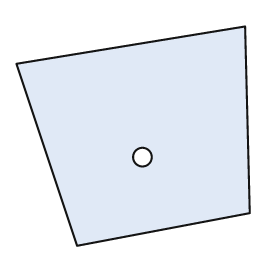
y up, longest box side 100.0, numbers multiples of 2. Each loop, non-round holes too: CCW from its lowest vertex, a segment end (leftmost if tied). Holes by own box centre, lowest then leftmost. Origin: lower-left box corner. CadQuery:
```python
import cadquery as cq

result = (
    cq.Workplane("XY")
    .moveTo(26.0, 0.0)
    .lineTo(100.0, 14.0)
    .lineTo(98.0, 94.0)
    .lineTo(0.0, 78.0)
    .close()
    .moveTo(54.0, 38.0)
    .circle(4.0)
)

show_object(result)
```